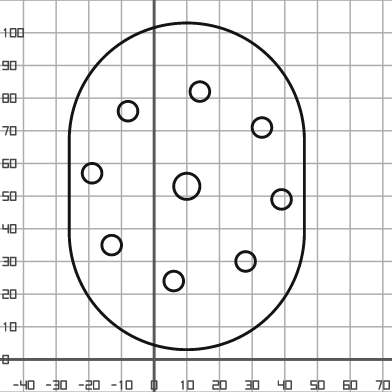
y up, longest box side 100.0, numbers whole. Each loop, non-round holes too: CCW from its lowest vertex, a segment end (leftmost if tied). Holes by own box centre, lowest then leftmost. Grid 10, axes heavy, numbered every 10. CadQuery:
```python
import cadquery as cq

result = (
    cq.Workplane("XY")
    .moveTo(-26.0, 39.0)
    .threePointArc((10.0, 3.0), (46.0, 39.0))
    .lineTo(46.0, 67.0)
    .threePointArc((10.0, 103.0), (-26.0, 67.0))
    .close()
    .moveTo(6.0, 24.0)
    .circle(3.0)
    .moveTo(28.0, 30.0)
    .circle(3.0)
    .moveTo(-13.0, 35.0)
    .circle(3.0)
    .moveTo(39.0, 49.0)
    .circle(3.0)
    .moveTo(10.0, 53.0)
    .circle(4.0)
    .moveTo(-19.0, 57.0)
    .circle(3.0)
    .moveTo(33.0, 71.0)
    .circle(3.0)
    .moveTo(-8.0, 76.0)
    .circle(3.0)
    .moveTo(14.0, 82.0)
    .circle(3.0)
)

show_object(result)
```